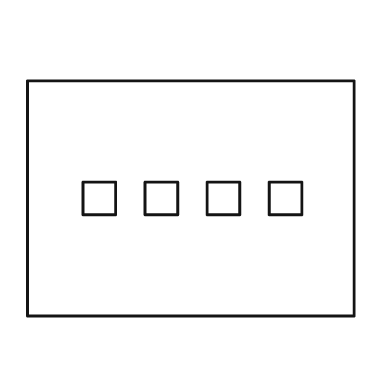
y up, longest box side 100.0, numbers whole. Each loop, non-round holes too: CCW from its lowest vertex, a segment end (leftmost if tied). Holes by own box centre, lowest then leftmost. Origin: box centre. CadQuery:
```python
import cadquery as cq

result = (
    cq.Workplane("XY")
    .moveTo(-50.0, -36.0)
    .lineTo(50.0, -36.0)
    .lineTo(50.0, 36.0)
    .lineTo(-50.0, 36.0)
    .close()
    .moveTo(-33.0, -5.0)
    .lineTo(-23.0, -5.0)
    .lineTo(-23.0, 5.0)
    .lineTo(-33.0, 5.0)
    .close()
    .moveTo(-14.0, -5.0)
    .lineTo(-4.0, -5.0)
    .lineTo(-4.0, 5.0)
    .lineTo(-14.0, 5.0)
    .close()
    .moveTo(5.0, -5.0)
    .lineTo(15.0, -5.0)
    .lineTo(15.0, 5.0)
    .lineTo(5.0, 5.0)
    .close()
    .moveTo(24.0, -5.0)
    .lineTo(34.0, -5.0)
    .lineTo(34.0, 5.0)
    .lineTo(24.0, 5.0)
    .close()
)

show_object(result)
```